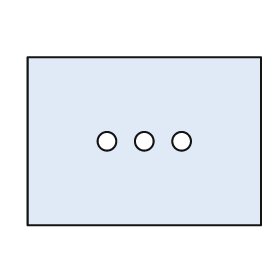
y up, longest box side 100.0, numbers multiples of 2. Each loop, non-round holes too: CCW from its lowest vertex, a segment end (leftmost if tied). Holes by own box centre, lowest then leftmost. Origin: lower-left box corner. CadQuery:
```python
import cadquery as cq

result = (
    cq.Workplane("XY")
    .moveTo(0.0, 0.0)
    .lineTo(100.0, 0.0)
    .lineTo(100.0, 72.0)
    .lineTo(0.0, 72.0)
    .close()
    .moveTo(34.0, 36.0)
    .circle(4.0)
    .moveTo(50.0, 36.0)
    .circle(4.0)
    .moveTo(66.0, 36.0)
    .circle(4.0)
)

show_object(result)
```